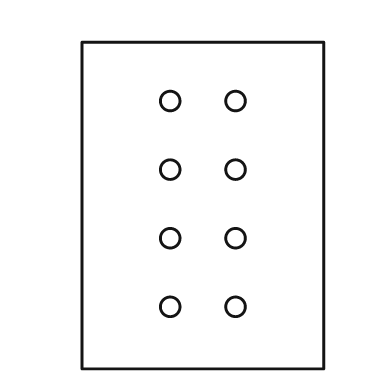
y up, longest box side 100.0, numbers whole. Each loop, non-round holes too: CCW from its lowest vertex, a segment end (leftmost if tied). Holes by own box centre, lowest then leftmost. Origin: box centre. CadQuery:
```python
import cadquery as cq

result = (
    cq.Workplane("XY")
    .moveTo(-37.0, -50.0)
    .lineTo(37.0, -50.0)
    .lineTo(37.0, 50.0)
    .lineTo(-37.0, 50.0)
    .close()
    .moveTo(-10.0, -31.0)
    .circle(3.0)
    .moveTo(10.0, -31.0)
    .circle(3.0)
    .moveTo(-10.0, -10.0)
    .circle(3.0)
    .moveTo(10.0, -10.0)
    .circle(3.0)
    .moveTo(-10.0, 11.0)
    .circle(3.0)
    .moveTo(10.0, 11.0)
    .circle(3.0)
    .moveTo(-10.0, 32.0)
    .circle(3.0)
    .moveTo(10.0, 32.0)
    .circle(3.0)
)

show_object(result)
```